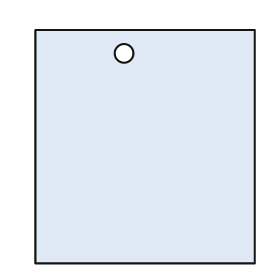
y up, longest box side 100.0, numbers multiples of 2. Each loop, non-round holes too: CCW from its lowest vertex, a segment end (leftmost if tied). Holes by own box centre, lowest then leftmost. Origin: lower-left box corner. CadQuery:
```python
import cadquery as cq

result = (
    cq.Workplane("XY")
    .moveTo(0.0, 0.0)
    .lineTo(94.0, 0.0)
    .lineTo(94.0, 100.0)
    .lineTo(0.0, 100.0)
    .close()
    .moveTo(38.0, 90.0)
    .circle(4.0)
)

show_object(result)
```